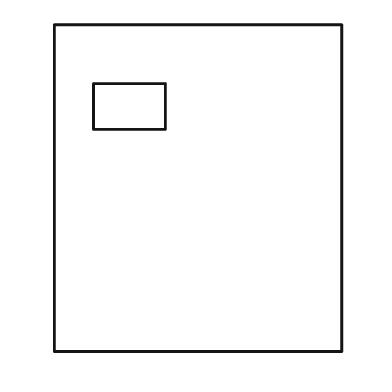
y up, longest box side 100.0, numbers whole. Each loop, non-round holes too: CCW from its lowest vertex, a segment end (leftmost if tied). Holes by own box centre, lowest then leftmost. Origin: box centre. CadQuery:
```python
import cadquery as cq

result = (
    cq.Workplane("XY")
    .moveTo(-44.0, -50.0)
    .lineTo(44.0, -50.0)
    .lineTo(44.0, 50.0)
    .lineTo(-44.0, 50.0)
    .close()
    .moveTo(-32.0, 18.0)
    .lineTo(-10.0, 18.0)
    .lineTo(-10.0, 32.0)
    .lineTo(-32.0, 32.0)
    .close()
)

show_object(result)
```